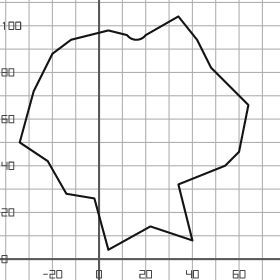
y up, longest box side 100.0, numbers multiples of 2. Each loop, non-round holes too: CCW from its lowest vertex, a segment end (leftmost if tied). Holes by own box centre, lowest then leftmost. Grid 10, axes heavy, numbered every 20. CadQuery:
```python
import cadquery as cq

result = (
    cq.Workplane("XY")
    .moveTo(4.0, 4.0)
    .lineTo(22.0, 14.0)
    .lineTo(40.0, 8.0)
    .lineTo(34.0, 32.0)
    .lineTo(54.0, 40.0)
    .lineTo(60.0, 46.0)
    .lineTo(64.0, 66.0)
    .lineTo(48.0, 82.0)
    .lineTo(42.0, 94.0)
    .lineTo(34.0, 104.0)
    .lineTo(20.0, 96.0)
    .threePointArc((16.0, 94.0), (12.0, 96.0))
    .lineTo(4.0, 98.0)
    .lineTo(-12.0, 94.0)
    .lineTo(-20.0, 88.0)
    .lineTo(-28.0, 72.0)
    .lineTo(-34.0, 50.0)
    .lineTo(-22.0, 42.0)
    .lineTo(-14.0, 28.0)
    .lineTo(-2.0, 26.0)
    .close()
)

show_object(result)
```